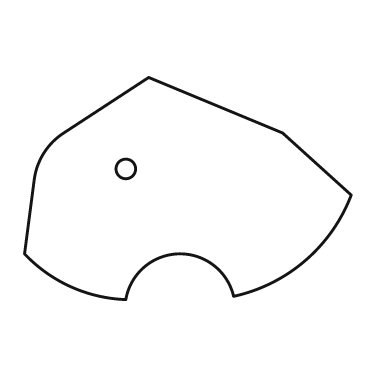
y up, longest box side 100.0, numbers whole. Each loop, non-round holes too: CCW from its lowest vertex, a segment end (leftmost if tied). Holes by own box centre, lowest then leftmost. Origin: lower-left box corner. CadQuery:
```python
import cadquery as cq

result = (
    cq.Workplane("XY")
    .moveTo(31.0, 0.0)
    .threePointArc((47.0, 14.0), (64.0, 1.0))
    .threePointArc((86.0, 12.0), (100.0, 32.0))
    .lineTo(79.0, 51.0)
    .lineTo(38.0, 68.0)
    .lineTo(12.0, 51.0)
    .threePointArc((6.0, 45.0), (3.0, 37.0))
    .lineTo(0.0, 14.0)
    .threePointArc((14.0, 4.0), (31.0, 0.0))
    .close()
    .moveTo(31.0, 40.0)
    .circle(3.0)
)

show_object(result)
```